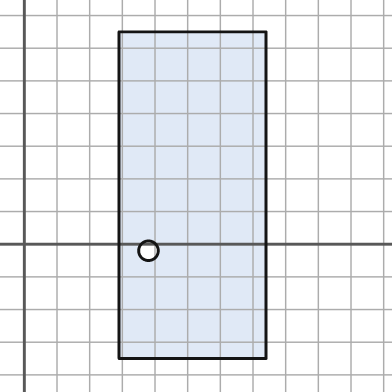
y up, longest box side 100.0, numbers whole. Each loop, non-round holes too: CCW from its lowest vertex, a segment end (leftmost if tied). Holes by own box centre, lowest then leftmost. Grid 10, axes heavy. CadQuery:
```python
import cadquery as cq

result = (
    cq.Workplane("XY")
    .moveTo(29.0, -35.0)
    .lineTo(74.0, -35.0)
    .lineTo(74.0, 65.0)
    .lineTo(29.0, 65.0)
    .close()
    .moveTo(38.0, -2.0)
    .circle(3.0)
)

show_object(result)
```